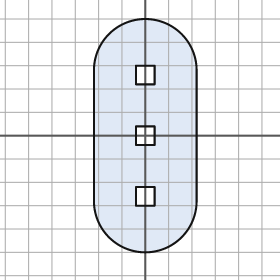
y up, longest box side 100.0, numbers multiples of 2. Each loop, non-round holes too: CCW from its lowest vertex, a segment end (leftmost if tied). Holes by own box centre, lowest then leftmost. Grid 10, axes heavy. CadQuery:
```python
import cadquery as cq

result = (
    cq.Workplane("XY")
    .moveTo(-22.0, -28.0)
    .threePointArc((0.0, -50.0), (22.0, -28.0))
    .lineTo(22.0, 28.0)
    .threePointArc((0.0, 50.0), (-22.0, 28.0))
    .close()
    .moveTo(-4.0, -30.0)
    .lineTo(4.0, -30.0)
    .lineTo(4.0, -22.0)
    .lineTo(-4.0, -22.0)
    .close()
    .moveTo(-4.0, -4.0)
    .lineTo(4.0, -4.0)
    .lineTo(4.0, 4.0)
    .lineTo(-4.0, 4.0)
    .close()
    .moveTo(-4.0, 22.0)
    .lineTo(4.0, 22.0)
    .lineTo(4.0, 30.0)
    .lineTo(-4.0, 30.0)
    .close()
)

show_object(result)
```